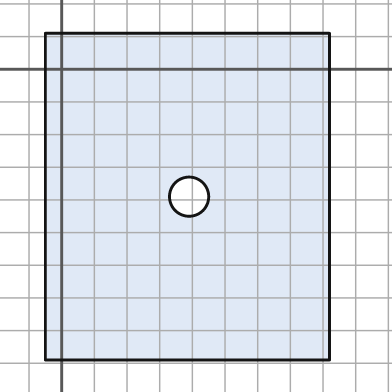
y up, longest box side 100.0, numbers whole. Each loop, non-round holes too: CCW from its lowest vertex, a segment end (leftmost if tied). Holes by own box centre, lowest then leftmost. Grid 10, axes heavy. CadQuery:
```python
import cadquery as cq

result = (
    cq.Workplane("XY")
    .moveTo(-5.0, -89.0)
    .lineTo(82.0, -89.0)
    .lineTo(82.0, 11.0)
    .lineTo(-5.0, 11.0)
    .close()
    .moveTo(39.0, -39.0)
    .circle(6.0)
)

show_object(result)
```